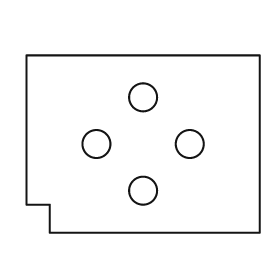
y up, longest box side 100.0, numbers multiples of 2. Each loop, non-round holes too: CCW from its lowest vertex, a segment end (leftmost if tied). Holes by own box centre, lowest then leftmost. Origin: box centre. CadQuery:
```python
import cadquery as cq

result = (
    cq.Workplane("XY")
    .moveTo(-40.0, -38.0)
    .lineTo(50.0, -38.0)
    .lineTo(50.0, 38.0)
    .lineTo(-50.0, 38.0)
    .lineTo(-50.0, -26.0)
    .lineTo(-40.0, -26.0)
    .close()
    .moveTo(0.0, -20.0)
    .circle(6.0)
    .moveTo(-20.0, 0.0)
    .circle(6.0)
    .moveTo(20.0, 0.0)
    .circle(6.0)
    .moveTo(0.0, 20.0)
    .circle(6.0)
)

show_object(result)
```